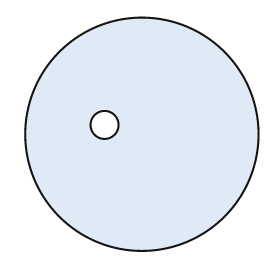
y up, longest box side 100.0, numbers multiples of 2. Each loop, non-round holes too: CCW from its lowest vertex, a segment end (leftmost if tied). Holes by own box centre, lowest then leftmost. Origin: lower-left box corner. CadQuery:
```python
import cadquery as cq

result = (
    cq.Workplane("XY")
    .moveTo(50.0, 50.0)
    .circle(50.0)
    .moveTo(34.0, 54.0)
    .circle(6.0)
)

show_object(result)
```